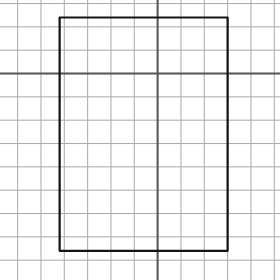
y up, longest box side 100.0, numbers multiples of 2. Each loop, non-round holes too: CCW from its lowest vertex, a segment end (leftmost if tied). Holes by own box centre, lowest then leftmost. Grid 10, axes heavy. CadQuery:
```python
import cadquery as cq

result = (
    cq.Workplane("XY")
    .moveTo(-42.0, -76.0)
    .lineTo(30.0, -76.0)
    .lineTo(30.0, 24.0)
    .lineTo(-42.0, 24.0)
    .close()
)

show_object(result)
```